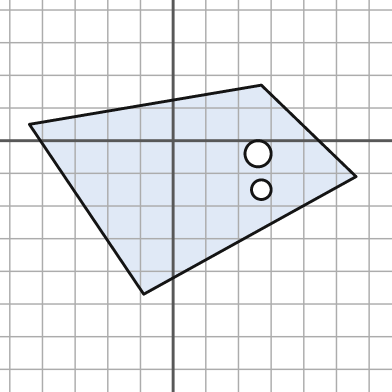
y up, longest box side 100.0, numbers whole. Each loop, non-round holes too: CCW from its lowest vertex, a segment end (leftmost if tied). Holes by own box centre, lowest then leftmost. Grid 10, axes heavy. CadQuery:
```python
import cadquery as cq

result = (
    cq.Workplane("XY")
    .moveTo(-9.0, -47.0)
    .lineTo(56.0, -11.0)
    .lineTo(27.0, 17.0)
    .lineTo(-44.0, 5.0)
    .close()
    .moveTo(27.0, -15.0)
    .circle(3.0)
    .moveTo(26.0, -4.0)
    .circle(4.0)
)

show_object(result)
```